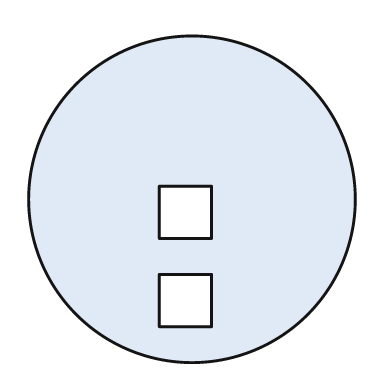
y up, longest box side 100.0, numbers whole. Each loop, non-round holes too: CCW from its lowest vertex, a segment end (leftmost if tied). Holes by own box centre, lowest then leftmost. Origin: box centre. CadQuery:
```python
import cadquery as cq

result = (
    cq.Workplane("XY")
    .moveTo(0.0, 0.0)
    .circle(50.0)
    .moveTo(-10.0, -39.0)
    .lineTo(6.0, -39.0)
    .lineTo(6.0, -23.0)
    .lineTo(-10.0, -23.0)
    .close()
    .moveTo(-10.0, -12.0)
    .lineTo(6.0, -12.0)
    .lineTo(6.0, 4.0)
    .lineTo(-10.0, 4.0)
    .close()
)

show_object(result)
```